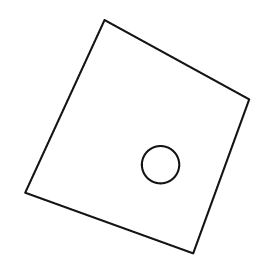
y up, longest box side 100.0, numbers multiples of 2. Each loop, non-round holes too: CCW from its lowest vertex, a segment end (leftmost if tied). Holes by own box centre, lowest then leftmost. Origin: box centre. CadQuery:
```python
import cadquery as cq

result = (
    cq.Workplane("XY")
    .moveTo(24.0, -50.0)
    .lineTo(48.0, 16.0)
    .lineTo(-14.0, 50.0)
    .lineTo(-48.0, -24.0)
    .close()
    .moveTo(10.0, -12.0)
    .circle(8.0)
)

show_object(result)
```